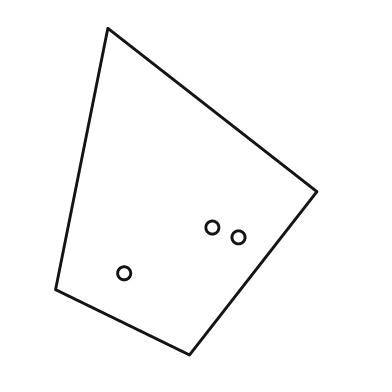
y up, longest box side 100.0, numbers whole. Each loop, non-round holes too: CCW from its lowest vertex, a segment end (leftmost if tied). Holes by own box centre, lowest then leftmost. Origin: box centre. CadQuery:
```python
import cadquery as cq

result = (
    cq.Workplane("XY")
    .moveTo(1.0, -50.0)
    .lineTo(40.0, 0.0)
    .lineTo(-24.0, 50.0)
    .lineTo(-40.0, -30.0)
    .close()
    .moveTo(-19.0, -25.0)
    .circle(2.0)
    .moveTo(16.0, -14.0)
    .circle(2.0)
    .moveTo(8.0, -11.0)
    .circle(2.0)
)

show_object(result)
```